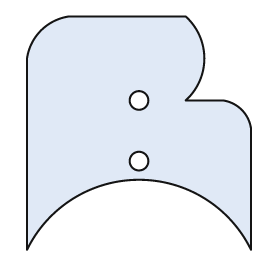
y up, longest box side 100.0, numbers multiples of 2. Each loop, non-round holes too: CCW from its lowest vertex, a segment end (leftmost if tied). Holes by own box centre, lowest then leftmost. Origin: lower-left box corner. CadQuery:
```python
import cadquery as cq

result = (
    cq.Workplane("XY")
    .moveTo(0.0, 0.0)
    .threePointArc((48.0, 30.0), (96.0, 0.0))
    .lineTo(96.0, 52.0)
    .threePointArc((92.0, 60.0), (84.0, 64.0))
    .lineTo(68.0, 64.0)
    .threePointArc((76.0, 82.0), (68.0, 100.0))
    .lineTo(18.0, 100.0)
    .threePointArc((6.0, 94.0), (0.0, 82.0))
    .close()
    .moveTo(48.0, 38.0)
    .circle(4.0)
    .moveTo(48.0, 64.0)
    .circle(4.0)
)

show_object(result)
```